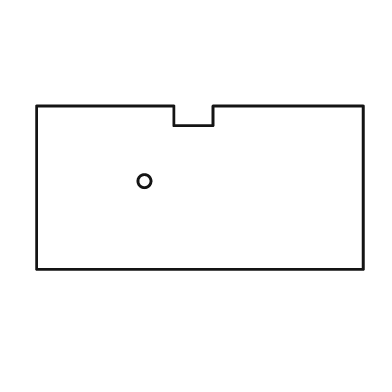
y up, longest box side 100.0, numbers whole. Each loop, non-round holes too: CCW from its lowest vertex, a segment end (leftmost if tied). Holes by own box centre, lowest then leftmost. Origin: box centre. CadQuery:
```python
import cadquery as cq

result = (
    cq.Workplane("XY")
    .moveTo(-50.0, -25.0)
    .lineTo(50.0, -25.0)
    .lineTo(50.0, 25.0)
    .lineTo(4.0, 25.0)
    .lineTo(4.0, 19.0)
    .lineTo(-8.0, 19.0)
    .lineTo(-8.0, 25.0)
    .lineTo(-50.0, 25.0)
    .close()
    .moveTo(-17.0, 2.0)
    .circle(2.0)
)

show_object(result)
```